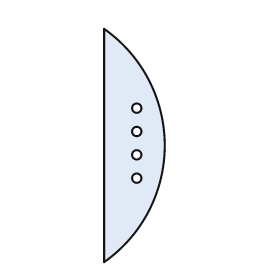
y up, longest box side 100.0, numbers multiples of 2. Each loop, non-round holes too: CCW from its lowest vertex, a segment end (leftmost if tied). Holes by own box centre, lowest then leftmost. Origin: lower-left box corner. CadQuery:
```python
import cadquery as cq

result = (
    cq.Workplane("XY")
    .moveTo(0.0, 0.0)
    .threePointArc((26.0, 50.0), (0.0, 100.0))
    .close()
    .moveTo(14.0, 36.0)
    .circle(2.0)
    .moveTo(14.0, 46.0)
    .circle(2.0)
    .moveTo(14.0, 56.0)
    .circle(2.0)
    .moveTo(14.0, 66.0)
    .circle(2.0)
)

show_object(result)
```